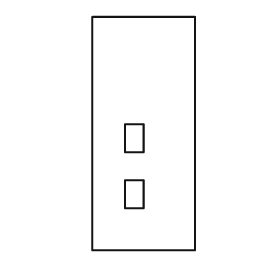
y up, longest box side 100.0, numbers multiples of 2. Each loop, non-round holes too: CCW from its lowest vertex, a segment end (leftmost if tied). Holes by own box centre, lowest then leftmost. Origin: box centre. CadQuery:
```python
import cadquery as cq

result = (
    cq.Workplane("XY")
    .moveTo(-22.0, -50.0)
    .lineTo(22.0, -50.0)
    .lineTo(22.0, 50.0)
    .lineTo(-22.0, 50.0)
    .close()
    .moveTo(-8.0, -32.0)
    .lineTo(0.0, -32.0)
    .lineTo(0.0, -20.0)
    .lineTo(-8.0, -20.0)
    .close()
    .moveTo(-8.0, -8.0)
    .lineTo(0.0, -8.0)
    .lineTo(0.0, 4.0)
    .lineTo(-8.0, 4.0)
    .close()
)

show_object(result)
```